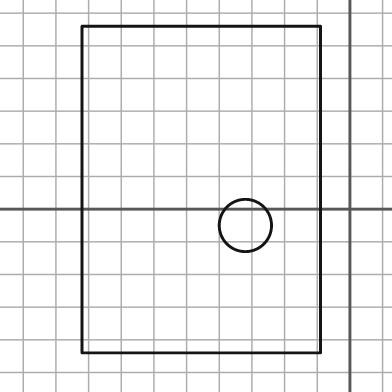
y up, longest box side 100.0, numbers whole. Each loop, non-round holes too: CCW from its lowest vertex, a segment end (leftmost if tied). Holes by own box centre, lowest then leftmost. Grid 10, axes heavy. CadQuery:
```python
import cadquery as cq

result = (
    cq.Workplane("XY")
    .moveTo(-82.0, -44.0)
    .lineTo(-9.0, -44.0)
    .lineTo(-9.0, 56.0)
    .lineTo(-82.0, 56.0)
    .close()
    .moveTo(-32.0, -5.0)
    .circle(8.0)
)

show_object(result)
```